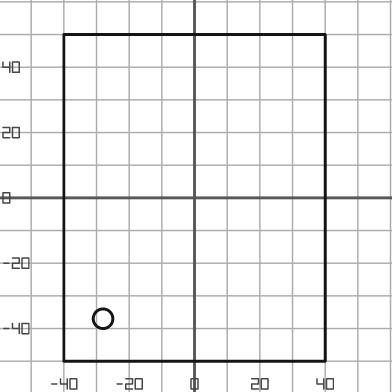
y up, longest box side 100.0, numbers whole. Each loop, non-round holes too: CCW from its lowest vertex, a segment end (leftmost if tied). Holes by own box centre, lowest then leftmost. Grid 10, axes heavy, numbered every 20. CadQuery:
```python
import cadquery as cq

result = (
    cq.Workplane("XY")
    .moveTo(-40.0, -50.0)
    .lineTo(40.0, -50.0)
    .lineTo(40.0, 50.0)
    .lineTo(-40.0, 50.0)
    .close()
    .moveTo(-28.0, -37.0)
    .circle(3.0)
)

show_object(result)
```